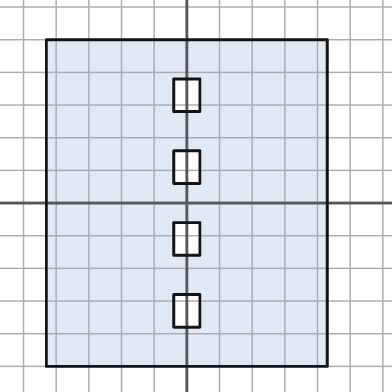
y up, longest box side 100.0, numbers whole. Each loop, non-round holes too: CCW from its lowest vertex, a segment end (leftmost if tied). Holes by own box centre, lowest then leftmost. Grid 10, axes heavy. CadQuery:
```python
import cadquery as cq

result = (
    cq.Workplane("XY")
    .moveTo(-43.0, -50.0)
    .lineTo(43.0, -50.0)
    .lineTo(43.0, 50.0)
    .lineTo(-43.0, 50.0)
    .close()
    .moveTo(-4.0, -38.0)
    .lineTo(4.0, -38.0)
    .lineTo(4.0, -28.0)
    .lineTo(-4.0, -28.0)
    .close()
    .moveTo(-4.0, -16.0)
    .lineTo(4.0, -16.0)
    .lineTo(4.0, -6.0)
    .lineTo(-4.0, -6.0)
    .close()
    .moveTo(-4.0, 6.0)
    .lineTo(4.0, 6.0)
    .lineTo(4.0, 16.0)
    .lineTo(-4.0, 16.0)
    .close()
    .moveTo(-4.0, 28.0)
    .lineTo(4.0, 28.0)
    .lineTo(4.0, 38.0)
    .lineTo(-4.0, 38.0)
    .close()
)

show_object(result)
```